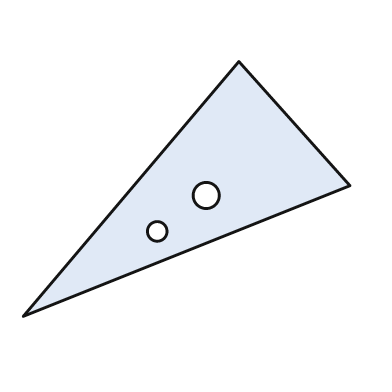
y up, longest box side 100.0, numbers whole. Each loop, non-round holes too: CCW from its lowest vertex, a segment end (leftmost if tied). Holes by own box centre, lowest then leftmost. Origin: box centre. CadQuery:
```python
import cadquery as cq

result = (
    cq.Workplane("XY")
    .moveTo(-50.0, -39.0)
    .lineTo(50.0, 1.0)
    .lineTo(16.0, 39.0)
    .close()
    .moveTo(-9.0, -13.0)
    .circle(3.0)
    .moveTo(6.0, -2.0)
    .circle(4.0)
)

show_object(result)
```